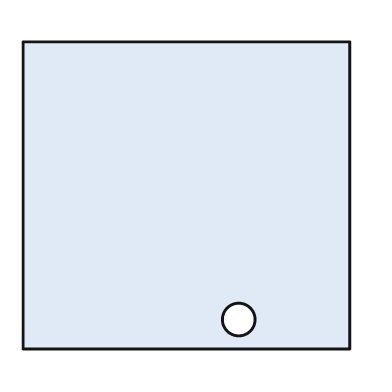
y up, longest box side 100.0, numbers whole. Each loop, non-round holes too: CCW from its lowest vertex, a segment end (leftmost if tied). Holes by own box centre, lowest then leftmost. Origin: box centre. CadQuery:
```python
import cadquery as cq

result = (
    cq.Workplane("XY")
    .moveTo(-50.0, -47.0)
    .lineTo(50.0, -47.0)
    .lineTo(50.0, 47.0)
    .lineTo(-50.0, 47.0)
    .close()
    .moveTo(16.0, -38.0)
    .circle(5.0)
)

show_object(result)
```